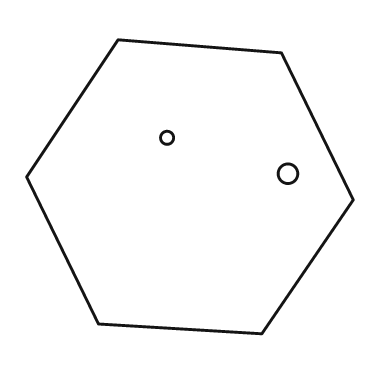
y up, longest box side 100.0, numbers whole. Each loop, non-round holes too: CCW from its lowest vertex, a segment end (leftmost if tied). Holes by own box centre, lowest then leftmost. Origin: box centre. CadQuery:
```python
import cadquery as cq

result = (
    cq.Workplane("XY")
    .moveTo(22.0, -45.0)
    .lineTo(50.0, -4.0)
    .lineTo(28.0, 41.0)
    .lineTo(-22.0, 45.0)
    .lineTo(-50.0, 3.0)
    .lineTo(-28.0, -42.0)
    .close()
    .moveTo(30.0, 4.0)
    .circle(3.0)
    .moveTo(-7.0, 15.0)
    .circle(2.0)
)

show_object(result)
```